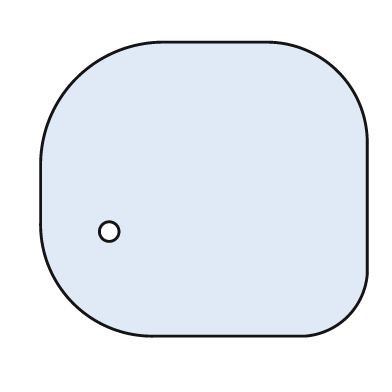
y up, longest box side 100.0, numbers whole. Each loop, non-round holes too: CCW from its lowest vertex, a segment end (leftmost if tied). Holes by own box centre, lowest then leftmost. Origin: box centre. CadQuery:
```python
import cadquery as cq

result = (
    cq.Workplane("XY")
    .moveTo(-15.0, -45.0)
    .lineTo(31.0, -45.0)
    .threePointArc((44.0, -39.0), (50.0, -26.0))
    .lineTo(50.0, 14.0)
    .threePointArc((41.0, 36.0), (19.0, 45.0))
    .lineTo(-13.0, 45.0)
    .threePointArc((-39.0, 34.0), (-50.0, 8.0))
    .lineTo(-50.0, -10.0)
    .threePointArc((-40.0, -35.0), (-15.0, -45.0))
    .close()
    .moveTo(-29.0, -13.0)
    .circle(3.0)
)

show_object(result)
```